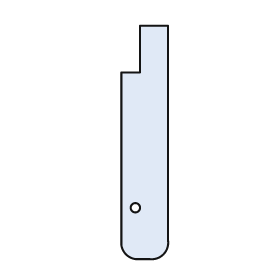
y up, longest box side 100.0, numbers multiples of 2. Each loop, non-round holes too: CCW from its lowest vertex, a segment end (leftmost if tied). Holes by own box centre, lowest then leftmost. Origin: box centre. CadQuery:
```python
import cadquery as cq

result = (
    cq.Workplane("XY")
    .moveTo(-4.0, -50.0)
    .lineTo(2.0, -50.0)
    .threePointArc((8.0, -48.0), (10.0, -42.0))
    .lineTo(10.0, 50.0)
    .lineTo(-2.0, 50.0)
    .lineTo(-2.0, 30.0)
    .lineTo(-10.0, 30.0)
    .lineTo(-10.0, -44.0)
    .threePointArc((-8.0, -48.0), (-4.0, -50.0))
    .close()
    .moveTo(-4.0, -28.0)
    .circle(2.0)
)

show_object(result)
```